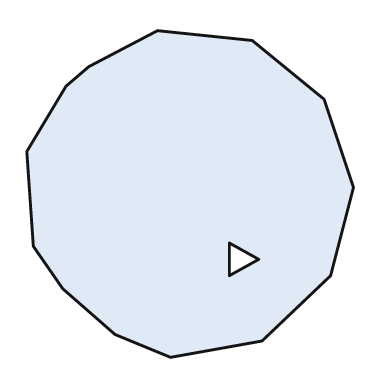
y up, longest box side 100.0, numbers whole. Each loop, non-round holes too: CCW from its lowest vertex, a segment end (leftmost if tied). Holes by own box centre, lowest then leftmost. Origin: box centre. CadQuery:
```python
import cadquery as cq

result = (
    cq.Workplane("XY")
    .moveTo(-6.0, -50.0)
    .lineTo(22.0, -45.0)
    .lineTo(43.0, -25.0)
    .lineTo(50.0, 2.0)
    .lineTo(41.0, 29.0)
    .lineTo(19.0, 47.0)
    .lineTo(-10.0, 50.0)
    .lineTo(-31.0, 39.0)
    .lineTo(-38.0, 33.0)
    .lineTo(-50.0, 13.0)
    .lineTo(-48.0, -16.0)
    .lineTo(-39.0, -29.0)
    .lineTo(-23.0, -43.0)
    .close()
    .moveTo(12.0, -25.0)
    .lineTo(21.0, -20.0)
    .lineTo(12.0, -15.0)
    .close()
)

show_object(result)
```